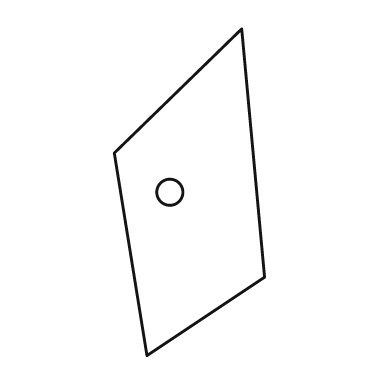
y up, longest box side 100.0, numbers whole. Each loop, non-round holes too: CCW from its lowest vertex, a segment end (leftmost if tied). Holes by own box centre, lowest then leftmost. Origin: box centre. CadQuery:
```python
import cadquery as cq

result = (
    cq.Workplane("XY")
    .moveTo(-13.0, -50.0)
    .lineTo(23.0, -26.0)
    .lineTo(16.0, 50.0)
    .lineTo(-23.0, 12.0)
    .close()
    .moveTo(-6.0, 0.0)
    .circle(4.0)
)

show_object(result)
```